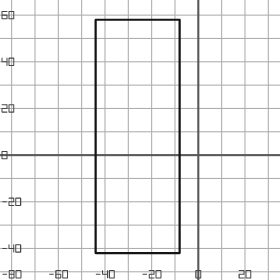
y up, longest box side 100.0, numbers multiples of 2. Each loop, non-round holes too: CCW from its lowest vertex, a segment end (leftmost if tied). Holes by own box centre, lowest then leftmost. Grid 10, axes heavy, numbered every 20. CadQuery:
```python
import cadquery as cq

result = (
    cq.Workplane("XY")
    .moveTo(-44.0, -42.0)
    .lineTo(-8.0, -42.0)
    .lineTo(-8.0, 58.0)
    .lineTo(-44.0, 58.0)
    .close()
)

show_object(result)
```